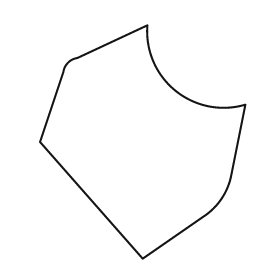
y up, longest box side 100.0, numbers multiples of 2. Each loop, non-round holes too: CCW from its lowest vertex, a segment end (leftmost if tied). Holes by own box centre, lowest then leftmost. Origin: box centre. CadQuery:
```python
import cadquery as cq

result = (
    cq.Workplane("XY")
    .moveTo(0.0, -50.0)
    .lineTo(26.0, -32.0)
    .threePointArc((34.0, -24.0), (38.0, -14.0))
    .lineTo(44.0, 16.0)
    .threePointArc((14.0, 22.0), (2.0, 50.0))
    .lineTo(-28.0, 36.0)
    .threePointArc((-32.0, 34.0), (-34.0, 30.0))
    .lineTo(-44.0, 0.0)
    .close()
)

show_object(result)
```